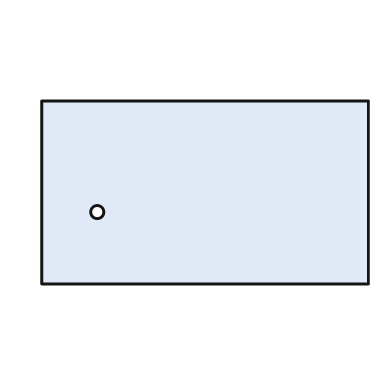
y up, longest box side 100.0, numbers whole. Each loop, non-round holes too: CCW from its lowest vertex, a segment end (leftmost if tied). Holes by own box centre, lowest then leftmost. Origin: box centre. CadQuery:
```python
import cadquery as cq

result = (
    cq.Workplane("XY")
    .moveTo(-50.0, -28.0)
    .lineTo(50.0, -28.0)
    .lineTo(50.0, 28.0)
    .lineTo(-50.0, 28.0)
    .close()
    .moveTo(-33.0, -6.0)
    .circle(2.0)
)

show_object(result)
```